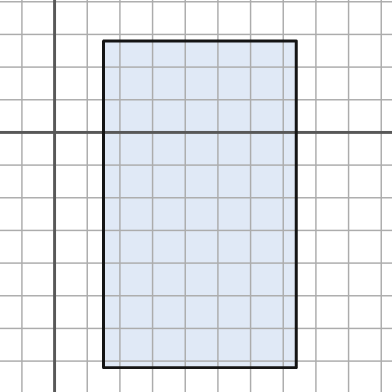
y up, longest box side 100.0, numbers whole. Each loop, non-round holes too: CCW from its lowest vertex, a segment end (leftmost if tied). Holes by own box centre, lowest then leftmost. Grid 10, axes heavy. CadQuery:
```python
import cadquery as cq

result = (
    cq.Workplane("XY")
    .moveTo(15.0, -72.0)
    .lineTo(74.0, -72.0)
    .lineTo(74.0, 28.0)
    .lineTo(15.0, 28.0)
    .close()
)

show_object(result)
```